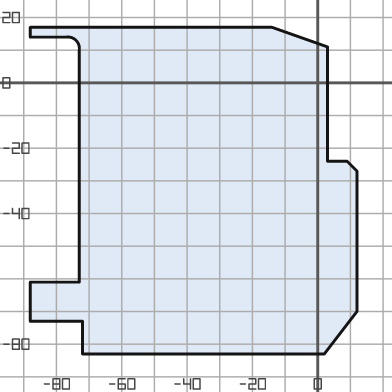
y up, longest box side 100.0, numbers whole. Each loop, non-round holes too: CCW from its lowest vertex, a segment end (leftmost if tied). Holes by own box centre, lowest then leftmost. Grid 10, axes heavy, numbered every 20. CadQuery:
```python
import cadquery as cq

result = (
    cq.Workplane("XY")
    .moveTo(-72.0, -83.0)
    .lineTo(2.0, -83.0)
    .lineTo(12.0, -70.0)
    .lineTo(12.0, -27.0)
    .lineTo(9.0, -24.0)
    .lineTo(3.0, -24.0)
    .lineTo(3.0, 11.0)
    .lineTo(-14.0, 17.0)
    .lineTo(-88.0, 17.0)
    .lineTo(-88.0, 14.0)
    .lineTo(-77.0, 14.0)
    .threePointArc((-74.0, 13.0), (-73.0, 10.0))
    .lineTo(-73.0, -61.0)
    .lineTo(-88.0, -61.0)
    .lineTo(-88.0, -73.0)
    .lineTo(-72.0, -73.0)
    .close()
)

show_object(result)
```